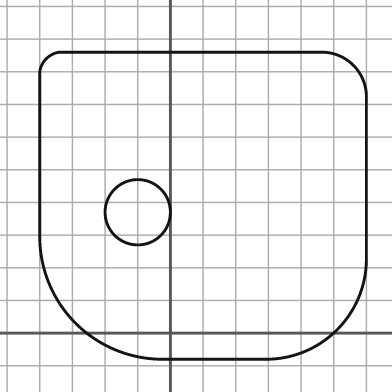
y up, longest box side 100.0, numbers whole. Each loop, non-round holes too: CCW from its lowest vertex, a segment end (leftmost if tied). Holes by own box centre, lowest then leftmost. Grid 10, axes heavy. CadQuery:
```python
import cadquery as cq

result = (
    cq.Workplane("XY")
    .moveTo(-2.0, -8.0)
    .lineTo(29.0, -8.0)
    .threePointArc((51.0, 1.0), (60.0, 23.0))
    .lineTo(60.0, 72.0)
    .threePointArc((56.0, 82.0), (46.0, 86.0))
    .lineTo(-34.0, 86.0)
    .threePointArc((-38.0, 84.0), (-40.0, 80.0))
    .lineTo(-40.0, 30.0)
    .threePointArc((-29.0, 3.0), (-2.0, -8.0))
    .close()
    .moveTo(-10.0, 37.0)
    .circle(10.0)
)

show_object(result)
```